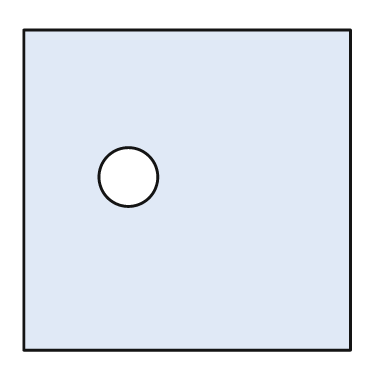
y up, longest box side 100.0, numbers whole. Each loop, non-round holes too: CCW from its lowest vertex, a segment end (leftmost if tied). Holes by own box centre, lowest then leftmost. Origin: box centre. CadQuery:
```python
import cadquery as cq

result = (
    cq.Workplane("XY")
    .moveTo(-50.0, -49.0)
    .lineTo(50.0, -49.0)
    .lineTo(50.0, 49.0)
    .lineTo(-50.0, 49.0)
    .close()
    .moveTo(-18.0, 4.0)
    .circle(9.0)
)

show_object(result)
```